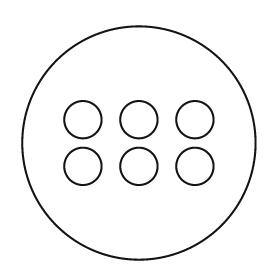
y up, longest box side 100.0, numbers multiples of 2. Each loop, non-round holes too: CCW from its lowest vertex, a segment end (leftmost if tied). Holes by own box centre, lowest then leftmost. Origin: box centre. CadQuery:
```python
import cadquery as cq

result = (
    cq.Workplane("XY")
    .moveTo(0.0, 0.0)
    .circle(50.0)
    .moveTo(-24.0, -10.0)
    .circle(8.0)
    .moveTo(0.0, -10.0)
    .circle(8.0)
    .moveTo(24.0, -10.0)
    .circle(8.0)
    .moveTo(-24.0, 10.0)
    .circle(8.0)
    .moveTo(0.0, 10.0)
    .circle(8.0)
    .moveTo(24.0, 10.0)
    .circle(8.0)
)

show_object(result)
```